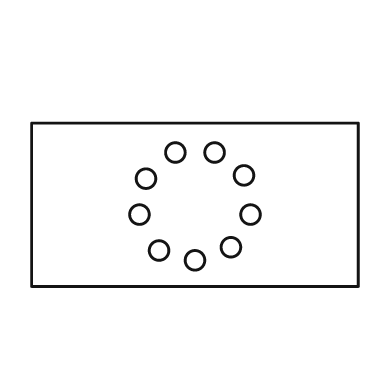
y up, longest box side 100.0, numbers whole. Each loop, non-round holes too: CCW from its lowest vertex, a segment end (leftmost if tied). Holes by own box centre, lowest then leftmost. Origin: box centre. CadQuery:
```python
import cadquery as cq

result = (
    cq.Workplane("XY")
    .moveTo(-50.0, -25.0)
    .lineTo(50.0, -25.0)
    .lineTo(50.0, 25.0)
    .lineTo(-50.0, 25.0)
    .close()
    .moveTo(0.0, -17.0)
    .circle(3.0)
    .moveTo(-11.0, -14.0)
    .circle(3.0)
    .moveTo(11.0, -13.0)
    .circle(3.0)
    .moveTo(-17.0, -3.0)
    .circle(3.0)
    .moveTo(17.0, -3.0)
    .circle(3.0)
    .moveTo(-15.0, 8.0)
    .circle(3.0)
    .moveTo(15.0, 9.0)
    .circle(3.0)
    .moveTo(-6.0, 16.0)
    .circle(3.0)
    .moveTo(6.0, 16.0)
    .circle(3.0)
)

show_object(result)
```